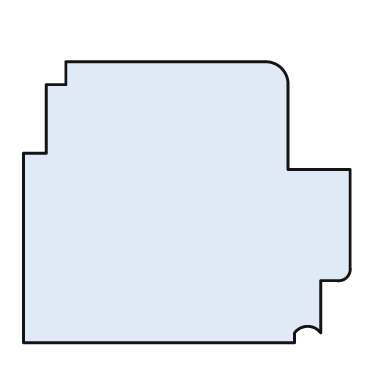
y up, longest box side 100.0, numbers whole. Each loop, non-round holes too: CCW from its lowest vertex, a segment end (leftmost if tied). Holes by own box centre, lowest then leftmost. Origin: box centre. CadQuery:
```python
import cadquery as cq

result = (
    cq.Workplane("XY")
    .moveTo(-50.0, -43.0)
    .lineTo(33.0, -43.0)
    .lineTo(33.0, -40.0)
    .threePointArc((37.0, -38.0), (41.0, -40.0))
    .lineTo(41.0, -24.0)
    .lineTo(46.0, -24.0)
    .threePointArc((49.0, -23.0), (50.0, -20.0))
    .lineTo(50.0, 10.0)
    .lineTo(31.0, 10.0)
    .lineTo(31.0, 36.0)
    .threePointArc((29.0, 41.0), (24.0, 43.0))
    .lineTo(-37.0, 43.0)
    .lineTo(-37.0, 36.0)
    .lineTo(-43.0, 36.0)
    .lineTo(-43.0, 15.0)
    .lineTo(-50.0, 15.0)
    .close()
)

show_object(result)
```